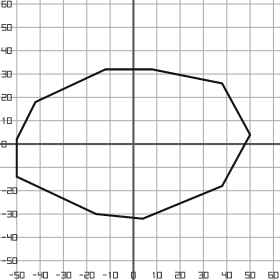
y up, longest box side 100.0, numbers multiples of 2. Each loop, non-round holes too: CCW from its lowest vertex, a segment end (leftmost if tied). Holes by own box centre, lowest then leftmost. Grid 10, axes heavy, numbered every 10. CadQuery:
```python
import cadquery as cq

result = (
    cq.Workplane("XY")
    .moveTo(4.0, -32.0)
    .lineTo(38.0, -18.0)
    .lineTo(50.0, 4.0)
    .lineTo(38.0, 26.0)
    .lineTo(8.0, 32.0)
    .lineTo(-12.0, 32.0)
    .lineTo(-42.0, 18.0)
    .lineTo(-50.0, 2.0)
    .lineTo(-50.0, -14.0)
    .lineTo(-16.0, -30.0)
    .close()
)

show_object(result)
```